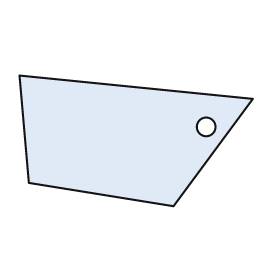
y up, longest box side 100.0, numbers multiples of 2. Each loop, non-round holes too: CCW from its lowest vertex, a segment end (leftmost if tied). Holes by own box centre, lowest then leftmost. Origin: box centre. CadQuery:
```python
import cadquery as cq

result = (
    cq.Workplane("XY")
    .moveTo(16.0, -28.0)
    .lineTo(50.0, 18.0)
    .lineTo(-50.0, 28.0)
    .lineTo(-46.0, -18.0)
    .close()
    .moveTo(30.0, 6.0)
    .circle(4.0)
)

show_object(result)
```